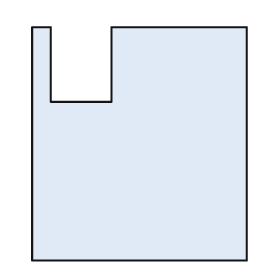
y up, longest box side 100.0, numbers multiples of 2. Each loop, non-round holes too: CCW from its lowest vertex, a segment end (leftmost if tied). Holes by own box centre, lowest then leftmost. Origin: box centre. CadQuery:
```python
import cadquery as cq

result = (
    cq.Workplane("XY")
    .moveTo(-46.0, -50.0)
    .lineTo(46.0, -50.0)
    .lineTo(46.0, 50.0)
    .lineTo(-12.0, 50.0)
    .lineTo(-12.0, 18.0)
    .lineTo(-38.0, 18.0)
    .lineTo(-38.0, 50.0)
    .lineTo(-46.0, 50.0)
    .close()
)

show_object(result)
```